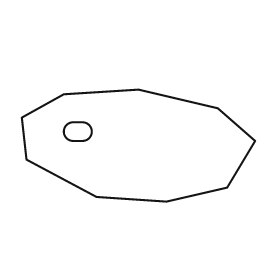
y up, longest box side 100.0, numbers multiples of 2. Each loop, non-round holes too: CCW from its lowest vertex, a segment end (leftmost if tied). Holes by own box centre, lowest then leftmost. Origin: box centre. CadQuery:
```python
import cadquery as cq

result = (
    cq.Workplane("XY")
    .moveTo(12.0, -24.0)
    .lineTo(38.0, -18.0)
    .lineTo(50.0, 2.0)
    .lineTo(34.0, 16.0)
    .lineTo(0.0, 24.0)
    .lineTo(-32.0, 22.0)
    .lineTo(-50.0, 12.0)
    .lineTo(-48.0, -6.0)
    .lineTo(-18.0, -22.0)
    .close()
    .moveTo(-28.0, 2.0)
    .lineTo(-24.0, 2.0)
    .threePointArc((-20.0, 6.0), (-24.0, 10.0))
    .lineTo(-28.0, 10.0)
    .threePointArc((-32.0, 6.0), (-28.0, 2.0))
    .close()
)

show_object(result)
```